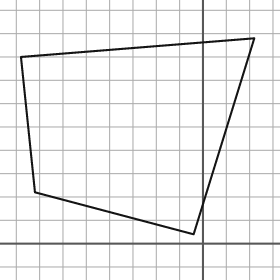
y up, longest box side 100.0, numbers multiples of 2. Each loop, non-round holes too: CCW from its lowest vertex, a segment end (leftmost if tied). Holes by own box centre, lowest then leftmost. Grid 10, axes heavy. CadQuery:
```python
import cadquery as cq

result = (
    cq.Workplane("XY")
    .moveTo(-4.0, 4.0)
    .lineTo(22.0, 88.0)
    .lineTo(-78.0, 80.0)
    .lineTo(-72.0, 22.0)
    .close()
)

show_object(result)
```